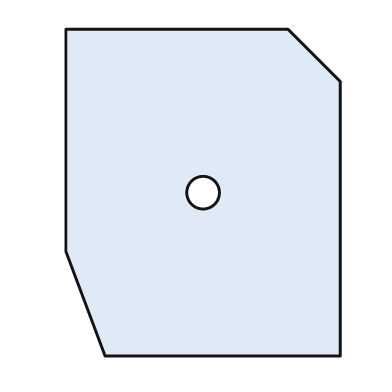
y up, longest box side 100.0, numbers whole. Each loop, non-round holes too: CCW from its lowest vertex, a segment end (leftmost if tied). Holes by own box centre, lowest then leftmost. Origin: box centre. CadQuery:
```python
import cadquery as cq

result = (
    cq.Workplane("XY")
    .moveTo(-30.0, -50.0)
    .lineTo(42.0, -50.0)
    .lineTo(42.0, 34.0)
    .lineTo(26.0, 50.0)
    .lineTo(-42.0, 50.0)
    .lineTo(-42.0, -18.0)
    .close()
    .moveTo(0.0, 0.0)
    .circle(5.0)
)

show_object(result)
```